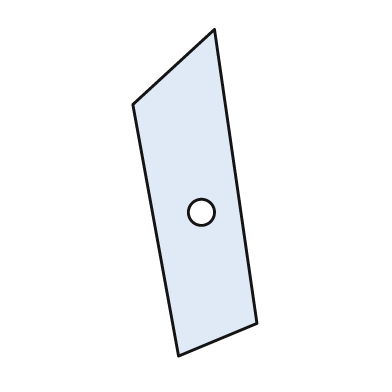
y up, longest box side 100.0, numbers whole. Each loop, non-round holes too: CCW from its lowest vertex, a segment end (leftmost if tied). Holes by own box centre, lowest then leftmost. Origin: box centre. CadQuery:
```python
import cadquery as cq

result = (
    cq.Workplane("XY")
    .moveTo(-5.0, -50.0)
    .lineTo(19.0, -40.0)
    .lineTo(6.0, 50.0)
    .lineTo(-19.0, 27.0)
    .close()
    .moveTo(2.0, -6.0)
    .circle(4.0)
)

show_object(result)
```